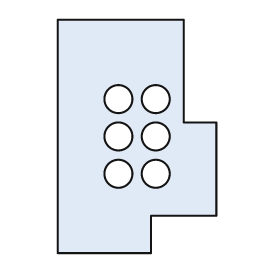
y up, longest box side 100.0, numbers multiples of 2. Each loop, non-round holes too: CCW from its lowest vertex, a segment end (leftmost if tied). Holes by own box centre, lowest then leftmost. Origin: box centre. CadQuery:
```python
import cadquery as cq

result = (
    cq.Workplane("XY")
    .moveTo(-34.0, -50.0)
    .lineTo(6.0, -50.0)
    .lineTo(6.0, -34.0)
    .lineTo(34.0, -34.0)
    .lineTo(34.0, 6.0)
    .lineTo(20.0, 6.0)
    .lineTo(20.0, 50.0)
    .lineTo(-34.0, 50.0)
    .close()
    .moveTo(-8.0, -16.0)
    .circle(6.0)
    .moveTo(8.0, -16.0)
    .circle(6.0)
    .moveTo(-8.0, 0.0)
    .circle(6.0)
    .moveTo(8.0, 0.0)
    .circle(6.0)
    .moveTo(-8.0, 16.0)
    .circle(6.0)
    .moveTo(8.0, 16.0)
    .circle(6.0)
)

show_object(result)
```